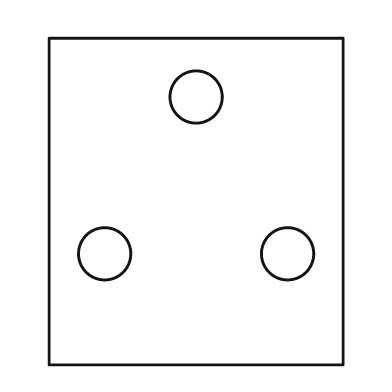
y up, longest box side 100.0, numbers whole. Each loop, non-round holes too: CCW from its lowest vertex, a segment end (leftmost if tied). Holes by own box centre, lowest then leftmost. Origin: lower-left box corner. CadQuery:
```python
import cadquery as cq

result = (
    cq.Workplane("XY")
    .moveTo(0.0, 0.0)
    .lineTo(90.0, 0.0)
    .lineTo(90.0, 100.0)
    .lineTo(0.0, 100.0)
    .close()
    .moveTo(17.0, 34.0)
    .circle(8.0)
    .moveTo(73.0, 34.0)
    .circle(8.0)
    .moveTo(45.0, 82.0)
    .circle(8.0)
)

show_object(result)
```